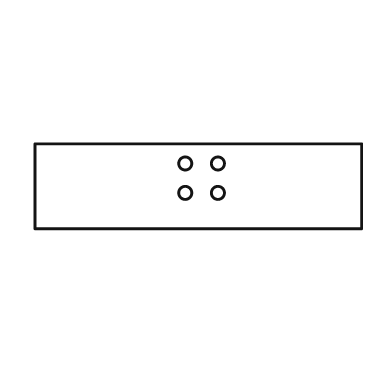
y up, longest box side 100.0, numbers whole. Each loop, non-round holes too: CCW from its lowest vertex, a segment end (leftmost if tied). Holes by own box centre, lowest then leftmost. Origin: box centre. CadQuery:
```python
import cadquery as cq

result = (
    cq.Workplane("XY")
    .moveTo(-50.0, -13.0)
    .lineTo(50.0, -13.0)
    .lineTo(50.0, 13.0)
    .lineTo(-50.0, 13.0)
    .close()
    .moveTo(-4.0, -2.0)
    .circle(2.0)
    .moveTo(6.0, -2.0)
    .circle(2.0)
    .moveTo(-4.0, 7.0)
    .circle(2.0)
    .moveTo(6.0, 7.0)
    .circle(2.0)
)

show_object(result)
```